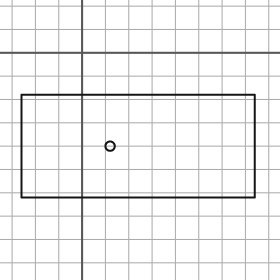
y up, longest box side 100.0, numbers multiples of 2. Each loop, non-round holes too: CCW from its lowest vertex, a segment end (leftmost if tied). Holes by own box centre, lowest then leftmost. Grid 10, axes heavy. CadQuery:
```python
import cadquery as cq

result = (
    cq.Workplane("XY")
    .moveTo(-26.0, -62.0)
    .lineTo(74.0, -62.0)
    .lineTo(74.0, -18.0)
    .lineTo(-26.0, -18.0)
    .close()
    .moveTo(12.0, -40.0)
    .circle(2.0)
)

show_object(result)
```